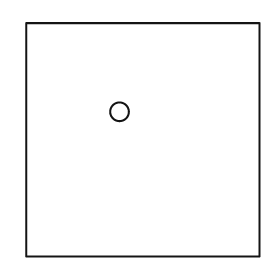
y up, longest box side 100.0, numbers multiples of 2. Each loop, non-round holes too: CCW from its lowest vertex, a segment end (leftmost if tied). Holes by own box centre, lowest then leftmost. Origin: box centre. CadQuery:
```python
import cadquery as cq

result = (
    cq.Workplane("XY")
    .moveTo(-50.0, -50.0)
    .lineTo(50.0, -50.0)
    .lineTo(50.0, 50.0)
    .lineTo(-50.0, 50.0)
    .close()
    .moveTo(-10.0, 12.0)
    .circle(4.0)
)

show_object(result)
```